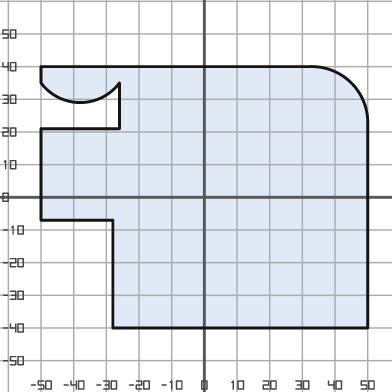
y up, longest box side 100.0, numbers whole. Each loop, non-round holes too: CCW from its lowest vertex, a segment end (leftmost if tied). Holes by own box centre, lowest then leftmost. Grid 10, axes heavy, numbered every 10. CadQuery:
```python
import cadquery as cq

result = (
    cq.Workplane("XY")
    .moveTo(-28.0, -40.0)
    .lineTo(50.0, -40.0)
    .lineTo(50.0, 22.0)
    .threePointArc((45.0, 35.0), (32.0, 40.0))
    .lineTo(-50.0, 40.0)
    .lineTo(-50.0, 35.0)
    .threePointArc((-38.0, 29.0), (-26.0, 35.0))
    .lineTo(-26.0, 21.0)
    .lineTo(-50.0, 21.0)
    .lineTo(-50.0, -7.0)
    .lineTo(-28.0, -7.0)
    .close()
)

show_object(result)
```